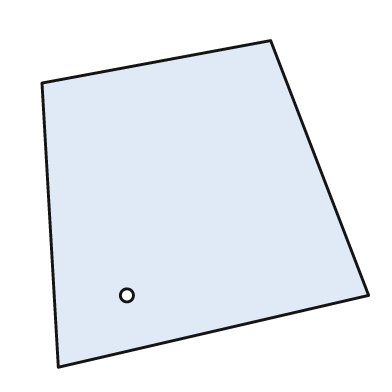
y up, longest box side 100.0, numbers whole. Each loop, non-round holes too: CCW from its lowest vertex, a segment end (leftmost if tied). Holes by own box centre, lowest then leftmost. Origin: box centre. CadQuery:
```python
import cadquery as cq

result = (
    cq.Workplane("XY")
    .moveTo(-45.0, -50.0)
    .lineTo(50.0, -28.0)
    .lineTo(20.0, 50.0)
    .lineTo(-50.0, 37.0)
    .close()
    .moveTo(-24.0, -28.0)
    .circle(2.0)
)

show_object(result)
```